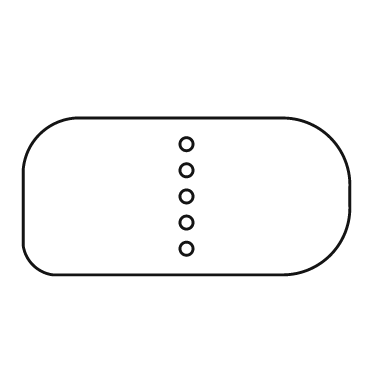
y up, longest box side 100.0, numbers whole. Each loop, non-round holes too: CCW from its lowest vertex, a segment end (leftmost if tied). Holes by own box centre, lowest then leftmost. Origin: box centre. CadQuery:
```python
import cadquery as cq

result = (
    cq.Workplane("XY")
    .moveTo(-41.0, -24.0)
    .lineTo(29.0, -24.0)
    .threePointArc((44.0, -18.0), (50.0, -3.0))
    .lineTo(50.0, 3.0)
    .threePointArc((44.0, 18.0), (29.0, 24.0))
    .lineTo(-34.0, 24.0)
    .threePointArc((-45.0, 19.0), (-50.0, 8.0))
    .lineTo(-50.0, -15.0)
    .threePointArc((-47.0, -21.0), (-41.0, -24.0))
    .close()
    .moveTo(0.0, -16.0)
    .circle(2.0)
    .moveTo(0.0, -8.0)
    .circle(2.0)
    .moveTo(0.0, 0.0)
    .circle(2.0)
    .moveTo(0.0, 8.0)
    .circle(2.0)
    .moveTo(0.0, 16.0)
    .circle(2.0)
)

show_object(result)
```